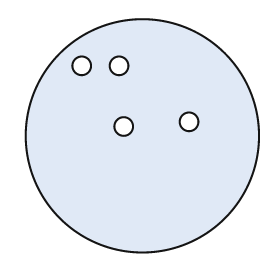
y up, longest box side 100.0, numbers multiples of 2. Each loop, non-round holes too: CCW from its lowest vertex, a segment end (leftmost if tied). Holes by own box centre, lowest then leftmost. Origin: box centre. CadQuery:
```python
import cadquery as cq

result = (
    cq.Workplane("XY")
    .moveTo(0.0, 0.0)
    .circle(50.0)
    .moveTo(-8.0, 4.0)
    .circle(4.0)
    .moveTo(20.0, 6.0)
    .circle(4.0)
    .moveTo(-26.0, 30.0)
    .circle(4.0)
    .moveTo(-10.0, 30.0)
    .circle(4.0)
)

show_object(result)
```